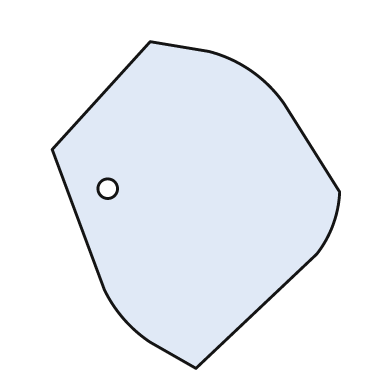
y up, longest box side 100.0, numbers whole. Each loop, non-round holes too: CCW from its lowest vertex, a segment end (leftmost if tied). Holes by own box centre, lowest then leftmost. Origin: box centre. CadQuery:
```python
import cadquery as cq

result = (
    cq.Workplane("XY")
    .moveTo(0.0, -50.0)
    .lineTo(37.0, -15.0)
    .threePointArc((42.0, -6.0), (44.0, 4.0))
    .lineTo(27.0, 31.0)
    .threePointArc((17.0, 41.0), (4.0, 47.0))
    .lineTo(-14.0, 50.0)
    .lineTo(-44.0, 17.0)
    .lineTo(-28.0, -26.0)
    .threePointArc((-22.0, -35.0), (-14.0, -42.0))
    .close()
    .moveTo(-27.0, 5.0)
    .circle(3.0)
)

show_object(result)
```